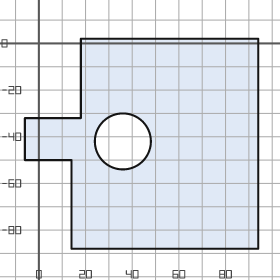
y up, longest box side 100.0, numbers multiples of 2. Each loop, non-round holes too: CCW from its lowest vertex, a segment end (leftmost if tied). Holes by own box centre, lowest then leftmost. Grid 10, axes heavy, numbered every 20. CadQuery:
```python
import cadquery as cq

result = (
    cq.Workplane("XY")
    .moveTo(14.0, -88.0)
    .lineTo(94.0, -88.0)
    .lineTo(94.0, 2.0)
    .lineTo(18.0, 2.0)
    .lineTo(18.0, -32.0)
    .lineTo(-6.0, -32.0)
    .lineTo(-6.0, -50.0)
    .lineTo(14.0, -50.0)
    .close()
    .moveTo(36.0, -42.0)
    .circle(12.0)
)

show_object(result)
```